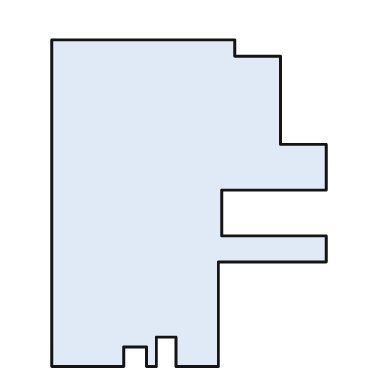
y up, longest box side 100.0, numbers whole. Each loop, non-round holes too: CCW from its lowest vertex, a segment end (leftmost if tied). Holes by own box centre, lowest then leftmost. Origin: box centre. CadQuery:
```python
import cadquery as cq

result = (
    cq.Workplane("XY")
    .moveTo(-42.0, -50.0)
    .lineTo(-20.0, -50.0)
    .lineTo(-20.0, -44.0)
    .lineTo(-13.0, -44.0)
    .lineTo(-13.0, -50.0)
    .lineTo(-10.0, -50.0)
    .lineTo(-10.0, -41.0)
    .lineTo(-4.0, -41.0)
    .lineTo(-4.0, -50.0)
    .lineTo(9.0, -50.0)
    .lineTo(9.0, -18.0)
    .lineTo(42.0, -18.0)
    .lineTo(42.0, -10.0)
    .lineTo(10.0, -10.0)
    .lineTo(10.0, 4.0)
    .lineTo(42.0, 4.0)
    .lineTo(42.0, 18.0)
    .lineTo(28.0, 18.0)
    .lineTo(28.0, 45.0)
    .lineTo(14.0, 45.0)
    .lineTo(14.0, 50.0)
    .lineTo(-42.0, 50.0)
    .close()
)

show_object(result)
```